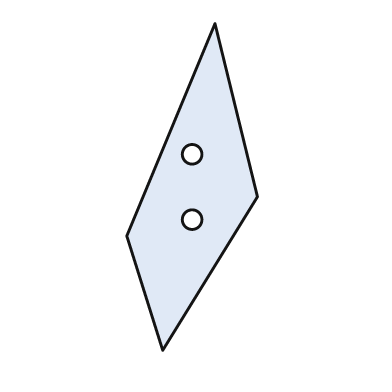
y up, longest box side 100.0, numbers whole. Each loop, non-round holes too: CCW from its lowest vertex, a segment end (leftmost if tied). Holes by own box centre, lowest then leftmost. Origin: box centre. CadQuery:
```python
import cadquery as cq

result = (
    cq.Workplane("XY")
    .moveTo(-9.0, -50.0)
    .lineTo(20.0, -3.0)
    .lineTo(7.0, 50.0)
    .lineTo(-20.0, -15.0)
    .close()
    .moveTo(0.0, -10.0)
    .circle(3.0)
    .moveTo(0.0, 10.0)
    .circle(3.0)
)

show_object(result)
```